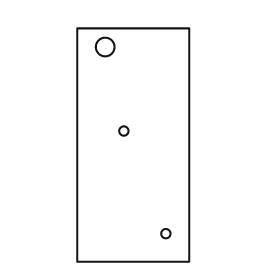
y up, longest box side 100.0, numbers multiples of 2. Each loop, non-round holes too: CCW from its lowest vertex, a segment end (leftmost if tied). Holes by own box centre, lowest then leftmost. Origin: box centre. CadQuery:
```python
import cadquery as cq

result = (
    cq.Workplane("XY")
    .moveTo(-24.0, -50.0)
    .lineTo(24.0, -50.0)
    .lineTo(24.0, 50.0)
    .lineTo(-24.0, 50.0)
    .close()
    .moveTo(14.0, -38.0)
    .circle(2.0)
    .moveTo(-4.0, 6.0)
    .circle(2.0)
    .moveTo(-12.0, 42.0)
    .circle(4.0)
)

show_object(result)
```